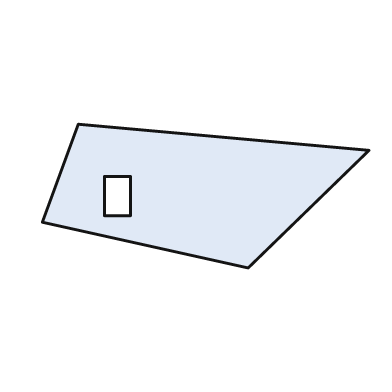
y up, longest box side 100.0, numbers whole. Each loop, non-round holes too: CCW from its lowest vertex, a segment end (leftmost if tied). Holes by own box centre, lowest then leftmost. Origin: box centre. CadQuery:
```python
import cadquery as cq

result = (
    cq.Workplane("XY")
    .moveTo(13.0, -22.0)
    .lineTo(50.0, 14.0)
    .lineTo(-39.0, 22.0)
    .lineTo(-50.0, -8.0)
    .close()
    .moveTo(-31.0, -6.0)
    .lineTo(-23.0, -6.0)
    .lineTo(-23.0, 6.0)
    .lineTo(-31.0, 6.0)
    .close()
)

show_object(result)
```